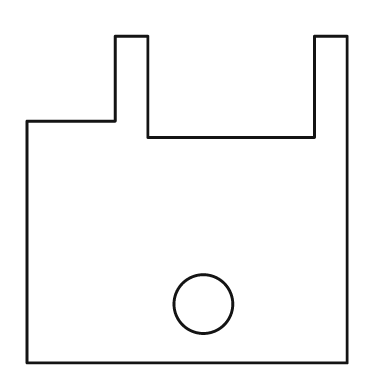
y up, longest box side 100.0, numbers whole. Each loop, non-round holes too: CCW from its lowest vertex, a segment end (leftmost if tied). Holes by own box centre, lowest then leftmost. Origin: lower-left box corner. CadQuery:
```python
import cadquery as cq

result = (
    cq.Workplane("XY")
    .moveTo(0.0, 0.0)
    .lineTo(98.0, 0.0)
    .lineTo(98.0, 100.0)
    .lineTo(88.0, 100.0)
    .lineTo(88.0, 69.0)
    .lineTo(37.0, 69.0)
    .lineTo(37.0, 100.0)
    .lineTo(27.0, 100.0)
    .lineTo(27.0, 74.0)
    .lineTo(0.0, 74.0)
    .close()
    .moveTo(54.0, 18.0)
    .circle(9.0)
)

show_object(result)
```